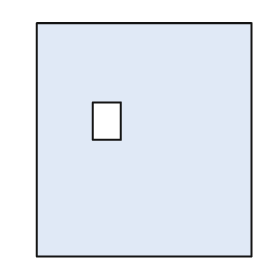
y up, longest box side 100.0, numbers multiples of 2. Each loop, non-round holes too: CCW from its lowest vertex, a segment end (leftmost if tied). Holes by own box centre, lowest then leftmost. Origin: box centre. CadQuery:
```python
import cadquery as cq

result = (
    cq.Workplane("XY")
    .moveTo(-46.0, -50.0)
    .lineTo(46.0, -50.0)
    .lineTo(46.0, 50.0)
    .lineTo(-46.0, 50.0)
    .close()
    .moveTo(-22.0, 0.0)
    .lineTo(-10.0, 0.0)
    .lineTo(-10.0, 16.0)
    .lineTo(-22.0, 16.0)
    .close()
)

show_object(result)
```